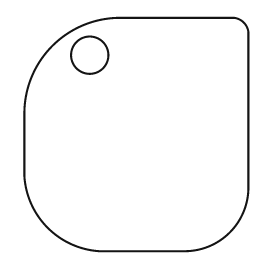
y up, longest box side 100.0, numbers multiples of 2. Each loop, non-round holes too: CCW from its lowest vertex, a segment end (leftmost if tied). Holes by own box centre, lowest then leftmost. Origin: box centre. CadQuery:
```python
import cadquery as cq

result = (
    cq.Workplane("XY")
    .moveTo(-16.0, -50.0)
    .lineTo(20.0, -50.0)
    .threePointArc((40.0, -42.0), (48.0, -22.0))
    .lineTo(48.0, 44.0)
    .threePointArc((46.0, 48.0), (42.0, 50.0))
    .lineTo(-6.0, 50.0)
    .threePointArc((-36.0, 38.0), (-48.0, 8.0))
    .lineTo(-48.0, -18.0)
    .threePointArc((-38.0, -40.0), (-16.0, -50.0))
    .close()
    .moveTo(-20.0, 34.0)
    .circle(8.0)
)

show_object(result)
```